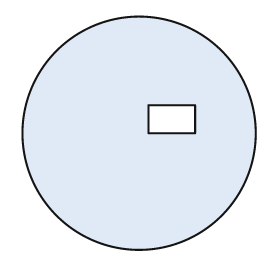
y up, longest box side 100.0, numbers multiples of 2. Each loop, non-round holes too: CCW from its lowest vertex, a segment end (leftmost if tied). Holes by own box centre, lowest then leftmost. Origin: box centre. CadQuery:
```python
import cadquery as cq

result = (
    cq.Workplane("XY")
    .moveTo(0.0, 0.0)
    .circle(50.0)
    .moveTo(4.0, 0.0)
    .lineTo(24.0, 0.0)
    .lineTo(24.0, 12.0)
    .lineTo(4.0, 12.0)
    .close()
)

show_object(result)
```